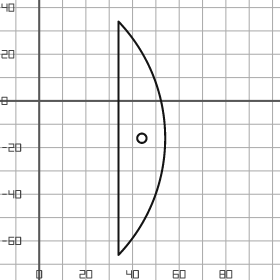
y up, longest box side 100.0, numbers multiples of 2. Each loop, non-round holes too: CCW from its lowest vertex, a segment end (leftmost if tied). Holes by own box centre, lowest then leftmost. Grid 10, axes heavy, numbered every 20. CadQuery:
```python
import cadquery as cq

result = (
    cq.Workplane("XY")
    .moveTo(34.0, -66.0)
    .threePointArc((54.0, -16.0), (34.0, 34.0))
    .close()
    .moveTo(44.0, -16.0)
    .circle(2.0)
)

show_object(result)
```